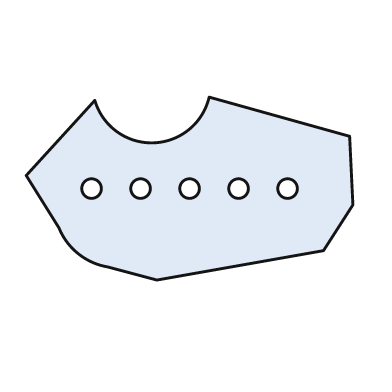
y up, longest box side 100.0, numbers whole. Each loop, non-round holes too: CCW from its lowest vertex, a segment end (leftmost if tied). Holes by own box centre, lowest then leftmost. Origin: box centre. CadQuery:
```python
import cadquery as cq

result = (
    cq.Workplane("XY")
    .moveTo(-10.0, -28.0)
    .lineTo(41.0, -19.0)
    .lineTo(50.0, -5.0)
    .lineTo(49.0, 16.0)
    .lineTo(6.0, 28.0)
    .threePointArc((-11.0, 14.0), (-29.0, 27.0))
    .lineTo(-50.0, 4.0)
    .lineTo(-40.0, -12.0)
    .threePointArc((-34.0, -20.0), (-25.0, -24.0))
    .close()
    .moveTo(-30.0, 0.0)
    .circle(3.0)
    .moveTo(-15.0, 0.0)
    .circle(3.0)
    .moveTo(0.0, 0.0)
    .circle(3.0)
    .moveTo(15.0, 0.0)
    .circle(3.0)
    .moveTo(30.0, 0.0)
    .circle(3.0)
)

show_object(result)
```